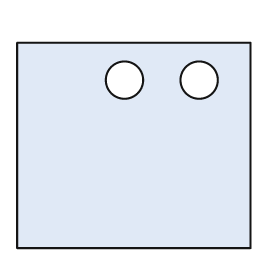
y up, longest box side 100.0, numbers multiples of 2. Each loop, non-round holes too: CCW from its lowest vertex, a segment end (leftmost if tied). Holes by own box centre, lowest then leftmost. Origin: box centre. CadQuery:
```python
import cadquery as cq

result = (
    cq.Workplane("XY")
    .moveTo(-50.0, -44.0)
    .lineTo(50.0, -44.0)
    .lineTo(50.0, 44.0)
    .lineTo(-50.0, 44.0)
    .close()
    .moveTo(-4.0, 28.0)
    .circle(8.0)
    .moveTo(28.0, 28.0)
    .circle(8.0)
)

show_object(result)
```